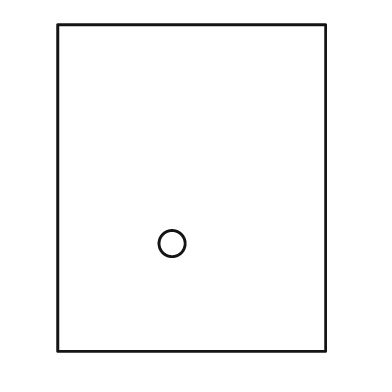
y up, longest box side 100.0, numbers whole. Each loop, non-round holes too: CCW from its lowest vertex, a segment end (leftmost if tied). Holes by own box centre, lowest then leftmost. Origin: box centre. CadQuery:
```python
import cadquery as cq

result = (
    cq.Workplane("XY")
    .moveTo(-41.0, -50.0)
    .lineTo(41.0, -50.0)
    .lineTo(41.0, 50.0)
    .lineTo(-41.0, 50.0)
    .close()
    .moveTo(-6.0, -17.0)
    .circle(4.0)
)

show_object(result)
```